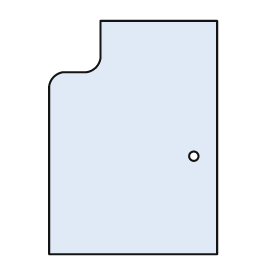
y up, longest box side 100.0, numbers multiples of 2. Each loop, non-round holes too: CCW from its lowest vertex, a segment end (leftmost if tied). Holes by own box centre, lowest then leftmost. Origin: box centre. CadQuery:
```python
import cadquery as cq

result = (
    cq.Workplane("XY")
    .moveTo(-36.0, -50.0)
    .lineTo(36.0, -50.0)
    .lineTo(36.0, 50.0)
    .lineTo(-14.0, 50.0)
    .lineTo(-14.0, 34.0)
    .threePointArc((-16.0, 30.0), (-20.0, 28.0))
    .lineTo(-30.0, 28.0)
    .threePointArc((-34.0, 26.0), (-36.0, 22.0))
    .close()
    .moveTo(26.0, -8.0)
    .circle(2.0)
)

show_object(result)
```